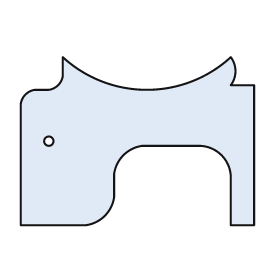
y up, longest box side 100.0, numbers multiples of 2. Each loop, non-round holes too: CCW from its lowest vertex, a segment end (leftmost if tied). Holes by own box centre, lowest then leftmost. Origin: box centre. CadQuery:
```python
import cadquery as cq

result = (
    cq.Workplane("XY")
    .moveTo(-50.0, -36.0)
    .lineTo(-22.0, -36.0)
    .threePointArc((-14.0, -32.0), (-10.0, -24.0))
    .lineTo(-10.0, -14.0)
    .threePointArc((-6.0, -6.0), (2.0, -2.0))
    .lineTo(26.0, -2.0)
    .threePointArc((36.0, -6.0), (40.0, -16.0))
    .lineTo(40.0, -36.0)
    .lineTo(50.0, -36.0)
    .lineTo(50.0, 24.0)
    .lineTo(40.0, 24.0)
    .threePointArc((42.0, 30.0), (40.0, 36.0))
    .threePointArc((4.0, 22.0), (-32.0, 36.0))
    .lineTo(-32.0, 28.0)
    .threePointArc((-34.0, 24.0), (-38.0, 22.0))
    .lineTo(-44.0, 22.0)
    .threePointArc((-48.0, 20.0), (-50.0, 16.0))
    .close()
    .moveTo(-38.0, 0.0)
    .circle(2.0)
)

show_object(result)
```